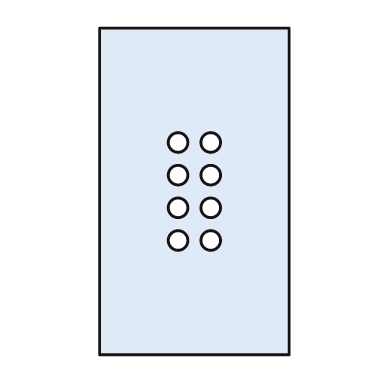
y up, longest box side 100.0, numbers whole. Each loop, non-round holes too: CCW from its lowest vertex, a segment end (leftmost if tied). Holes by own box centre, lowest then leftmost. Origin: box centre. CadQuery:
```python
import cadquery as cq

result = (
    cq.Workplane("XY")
    .moveTo(-29.0, -50.0)
    .lineTo(29.0, -50.0)
    .lineTo(29.0, 50.0)
    .lineTo(-29.0, 50.0)
    .close()
    .moveTo(-5.0, -15.0)
    .circle(3.0)
    .moveTo(5.0, -15.0)
    .circle(3.0)
    .moveTo(-5.0, -5.0)
    .circle(3.0)
    .moveTo(5.0, -5.0)
    .circle(3.0)
    .moveTo(-5.0, 5.0)
    .circle(3.0)
    .moveTo(5.0, 5.0)
    .circle(3.0)
    .moveTo(-5.0, 15.0)
    .circle(3.0)
    .moveTo(5.0, 15.0)
    .circle(3.0)
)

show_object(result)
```